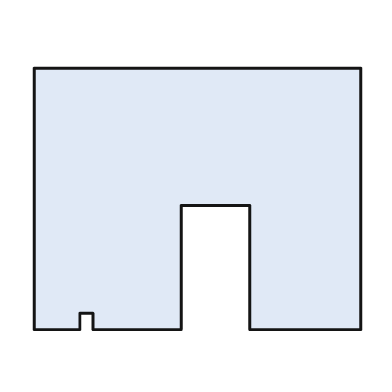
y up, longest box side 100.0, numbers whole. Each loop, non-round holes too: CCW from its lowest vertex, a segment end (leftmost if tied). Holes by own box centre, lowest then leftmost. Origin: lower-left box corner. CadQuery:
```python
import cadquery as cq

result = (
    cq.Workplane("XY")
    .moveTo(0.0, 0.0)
    .lineTo(14.0, 0.0)
    .lineTo(14.0, 5.0)
    .lineTo(18.0, 5.0)
    .lineTo(18.0, 0.0)
    .lineTo(45.0, 0.0)
    .lineTo(45.0, 38.0)
    .lineTo(66.0, 38.0)
    .lineTo(66.0, 0.0)
    .lineTo(100.0, 0.0)
    .lineTo(100.0, 80.0)
    .lineTo(0.0, 80.0)
    .close()
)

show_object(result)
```